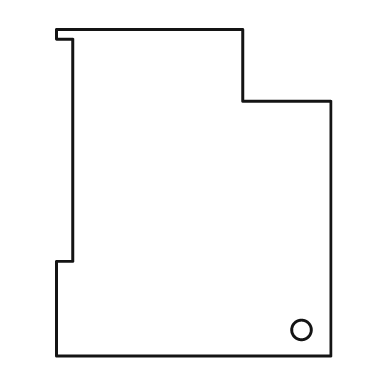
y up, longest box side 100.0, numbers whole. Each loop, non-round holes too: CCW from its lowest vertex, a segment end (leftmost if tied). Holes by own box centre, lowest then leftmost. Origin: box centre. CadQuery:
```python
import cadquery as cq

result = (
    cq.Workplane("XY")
    .moveTo(-42.0, -50.0)
    .lineTo(42.0, -50.0)
    .lineTo(42.0, 28.0)
    .lineTo(15.0, 28.0)
    .lineTo(15.0, 50.0)
    .lineTo(-42.0, 50.0)
    .lineTo(-42.0, 47.0)
    .lineTo(-37.0, 47.0)
    .lineTo(-37.0, -21.0)
    .lineTo(-42.0, -21.0)
    .close()
    .moveTo(33.0, -42.0)
    .circle(3.0)
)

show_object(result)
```